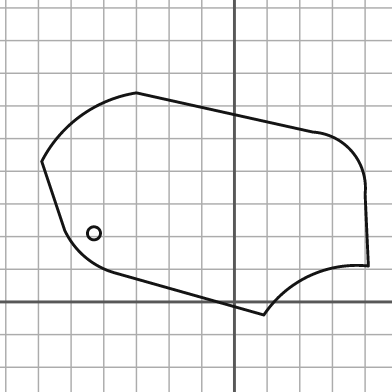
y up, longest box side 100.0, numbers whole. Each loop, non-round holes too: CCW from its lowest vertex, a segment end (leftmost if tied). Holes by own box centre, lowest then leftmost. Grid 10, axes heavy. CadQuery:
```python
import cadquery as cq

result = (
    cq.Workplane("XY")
    .moveTo(9.0, -4.0)
    .threePointArc((23.0, 8.0), (41.0, 11.0))
    .lineTo(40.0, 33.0)
    .threePointArc((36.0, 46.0), (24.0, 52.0))
    .lineTo(-30.0, 64.0)
    .threePointArc((-47.0, 57.0), (-59.0, 43.0))
    .lineTo(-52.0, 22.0)
    .threePointArc((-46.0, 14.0), (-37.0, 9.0))
    .close()
    .moveTo(-43.0, 21.0)
    .circle(2.0)
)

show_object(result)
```